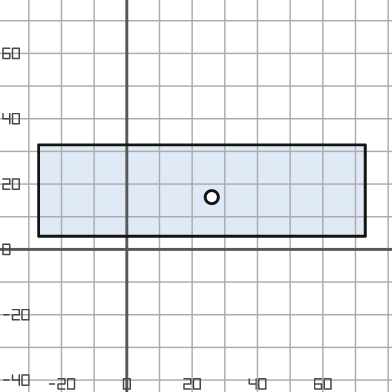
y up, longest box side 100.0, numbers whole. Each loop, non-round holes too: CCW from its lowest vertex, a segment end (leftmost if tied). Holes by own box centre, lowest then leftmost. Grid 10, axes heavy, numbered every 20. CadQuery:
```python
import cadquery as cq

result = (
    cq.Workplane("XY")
    .moveTo(-27.0, 4.0)
    .lineTo(73.0, 4.0)
    .lineTo(73.0, 32.0)
    .lineTo(-27.0, 32.0)
    .close()
    .moveTo(26.0, 16.0)
    .circle(2.0)
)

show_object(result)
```